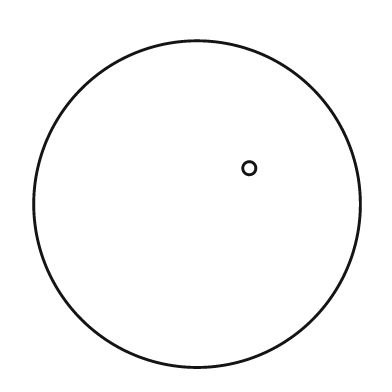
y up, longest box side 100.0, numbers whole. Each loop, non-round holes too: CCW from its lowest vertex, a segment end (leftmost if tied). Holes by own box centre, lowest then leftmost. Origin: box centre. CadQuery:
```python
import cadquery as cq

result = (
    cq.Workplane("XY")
    .moveTo(0.0, 0.0)
    .circle(50.0)
    .moveTo(16.0, 11.0)
    .circle(2.0)
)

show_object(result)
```